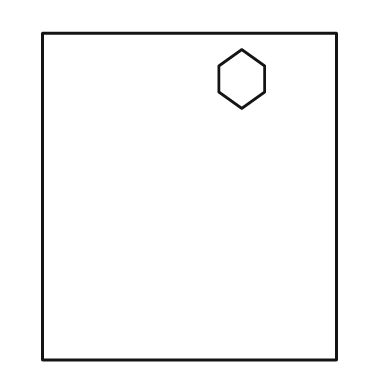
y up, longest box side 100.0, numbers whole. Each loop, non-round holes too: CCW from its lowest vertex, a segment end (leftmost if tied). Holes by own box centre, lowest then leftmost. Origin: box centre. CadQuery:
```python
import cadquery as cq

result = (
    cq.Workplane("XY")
    .moveTo(-45.0, -50.0)
    .lineTo(45.0, -50.0)
    .lineTo(45.0, 50.0)
    .lineTo(-45.0, 50.0)
    .close()
    .moveTo(16.0, 27.0)
    .lineTo(23.0, 32.0)
    .lineTo(23.0, 40.0)
    .lineTo(16.0, 45.0)
    .lineTo(9.0, 40.0)
    .lineTo(9.0, 32.0)
    .close()
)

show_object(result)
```